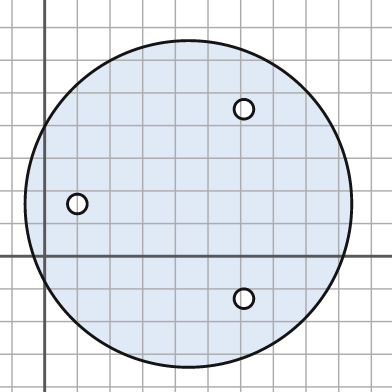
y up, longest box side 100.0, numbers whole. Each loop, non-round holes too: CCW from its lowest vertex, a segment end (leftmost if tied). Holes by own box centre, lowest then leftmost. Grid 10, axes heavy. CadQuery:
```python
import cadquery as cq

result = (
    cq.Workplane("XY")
    .moveTo(44.0, 16.0)
    .circle(50.0)
    .moveTo(61.0, -13.0)
    .circle(3.0)
    .moveTo(10.0, 16.0)
    .circle(3.0)
    .moveTo(61.0, 45.0)
    .circle(3.0)
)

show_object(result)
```